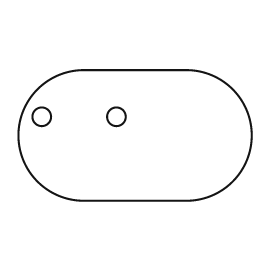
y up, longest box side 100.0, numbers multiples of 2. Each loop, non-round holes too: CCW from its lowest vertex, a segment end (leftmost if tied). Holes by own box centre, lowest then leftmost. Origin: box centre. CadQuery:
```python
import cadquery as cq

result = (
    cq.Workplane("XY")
    .moveTo(-22.0, -28.0)
    .lineTo(22.0, -28.0)
    .threePointArc((50.0, 0.0), (22.0, 28.0))
    .lineTo(-22.0, 28.0)
    .threePointArc((-50.0, 0.0), (-22.0, -28.0))
    .close()
    .moveTo(-40.0, 8.0)
    .circle(4.0)
    .moveTo(-8.0, 8.0)
    .circle(4.0)
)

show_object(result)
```